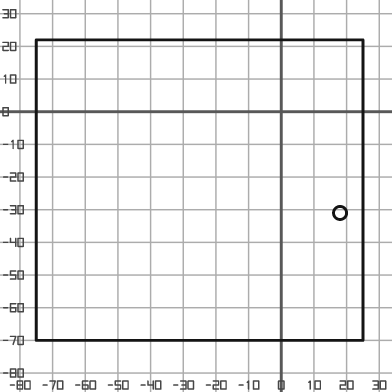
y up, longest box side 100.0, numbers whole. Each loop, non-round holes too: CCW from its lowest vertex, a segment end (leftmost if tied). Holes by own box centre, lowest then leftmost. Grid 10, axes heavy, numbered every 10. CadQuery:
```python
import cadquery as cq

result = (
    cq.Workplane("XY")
    .moveTo(-75.0, -70.0)
    .lineTo(25.0, -70.0)
    .lineTo(25.0, 22.0)
    .lineTo(-75.0, 22.0)
    .close()
    .moveTo(18.0, -31.0)
    .circle(2.0)
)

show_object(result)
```